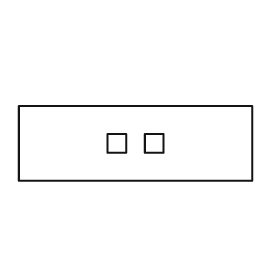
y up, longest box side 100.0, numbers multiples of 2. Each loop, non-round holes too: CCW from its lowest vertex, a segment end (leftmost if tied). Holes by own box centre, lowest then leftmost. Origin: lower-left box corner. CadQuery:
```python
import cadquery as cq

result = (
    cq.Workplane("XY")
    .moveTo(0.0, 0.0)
    .lineTo(100.0, 0.0)
    .lineTo(100.0, 32.0)
    .lineTo(0.0, 32.0)
    .close()
    .moveTo(38.0, 12.0)
    .lineTo(46.0, 12.0)
    .lineTo(46.0, 20.0)
    .lineTo(38.0, 20.0)
    .close()
    .moveTo(54.0, 12.0)
    .lineTo(62.0, 12.0)
    .lineTo(62.0, 20.0)
    .lineTo(54.0, 20.0)
    .close()
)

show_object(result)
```